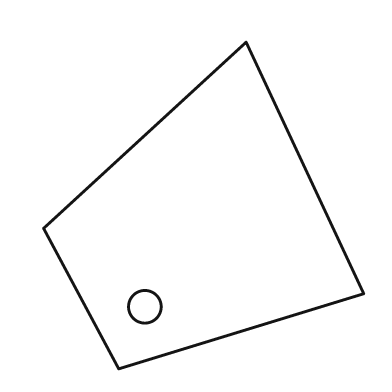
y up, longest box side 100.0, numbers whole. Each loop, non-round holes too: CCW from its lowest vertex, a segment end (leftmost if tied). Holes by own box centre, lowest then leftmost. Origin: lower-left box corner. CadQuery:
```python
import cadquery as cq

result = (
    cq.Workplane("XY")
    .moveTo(23.0, 0.0)
    .lineTo(98.0, 23.0)
    .lineTo(62.0, 100.0)
    .lineTo(0.0, 43.0)
    .close()
    .moveTo(31.0, 19.0)
    .circle(5.0)
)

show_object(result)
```